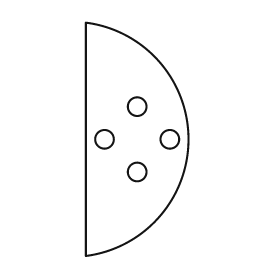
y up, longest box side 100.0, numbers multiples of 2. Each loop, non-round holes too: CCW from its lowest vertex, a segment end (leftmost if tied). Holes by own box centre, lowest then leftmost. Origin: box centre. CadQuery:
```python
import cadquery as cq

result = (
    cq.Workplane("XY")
    .moveTo(-22.0, -50.0)
    .threePointArc((22.0, 0.0), (-22.0, 50.0))
    .close()
    .moveTo(0.0, -14.0)
    .circle(4.0)
    .moveTo(-14.0, 0.0)
    .circle(4.0)
    .moveTo(14.0, 0.0)
    .circle(4.0)
    .moveTo(0.0, 14.0)
    .circle(4.0)
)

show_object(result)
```